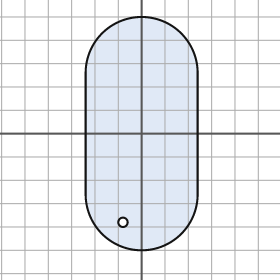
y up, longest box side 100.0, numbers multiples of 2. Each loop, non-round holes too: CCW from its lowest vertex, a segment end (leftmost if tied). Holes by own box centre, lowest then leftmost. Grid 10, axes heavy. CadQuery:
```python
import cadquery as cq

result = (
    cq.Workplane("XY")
    .moveTo(-24.0, -26.0)
    .threePointArc((0.0, -50.0), (24.0, -26.0))
    .lineTo(24.0, 26.0)
    .threePointArc((0.0, 50.0), (-24.0, 26.0))
    .close()
    .moveTo(-8.0, -38.0)
    .circle(2.0)
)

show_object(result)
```